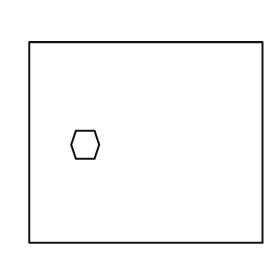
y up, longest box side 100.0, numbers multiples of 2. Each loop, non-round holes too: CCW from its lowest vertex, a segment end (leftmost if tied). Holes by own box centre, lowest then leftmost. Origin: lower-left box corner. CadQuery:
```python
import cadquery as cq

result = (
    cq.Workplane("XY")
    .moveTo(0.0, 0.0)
    .lineTo(100.0, 0.0)
    .lineTo(100.0, 86.0)
    .lineTo(0.0, 86.0)
    .close()
    .moveTo(20.0, 36.0)
    .lineTo(28.0, 36.0)
    .lineTo(30.0, 42.0)
    .lineTo(28.0, 48.0)
    .lineTo(20.0, 48.0)
    .lineTo(18.0, 42.0)
    .close()
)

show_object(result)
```